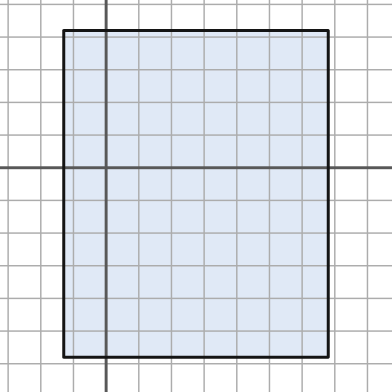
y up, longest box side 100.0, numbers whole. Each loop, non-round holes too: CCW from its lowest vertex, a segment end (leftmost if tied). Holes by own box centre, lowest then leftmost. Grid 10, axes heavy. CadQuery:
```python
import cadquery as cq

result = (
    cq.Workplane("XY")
    .moveTo(-13.0, -58.0)
    .lineTo(68.0, -58.0)
    .lineTo(68.0, 42.0)
    .lineTo(-13.0, 42.0)
    .close()
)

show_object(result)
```